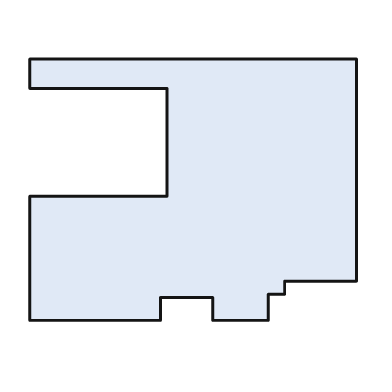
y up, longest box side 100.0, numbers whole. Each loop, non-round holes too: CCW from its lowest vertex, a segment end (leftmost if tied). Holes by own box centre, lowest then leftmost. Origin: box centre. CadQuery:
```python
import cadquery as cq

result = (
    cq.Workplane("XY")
    .moveTo(-50.0, -40.0)
    .lineTo(-10.0, -40.0)
    .lineTo(-10.0, -33.0)
    .lineTo(6.0, -33.0)
    .lineTo(6.0, -40.0)
    .lineTo(23.0, -40.0)
    .lineTo(23.0, -32.0)
    .lineTo(28.0, -32.0)
    .lineTo(28.0, -28.0)
    .lineTo(50.0, -28.0)
    .lineTo(50.0, 40.0)
    .lineTo(-50.0, 40.0)
    .lineTo(-50.0, 31.0)
    .lineTo(-8.0, 31.0)
    .lineTo(-8.0, -2.0)
    .lineTo(-50.0, -2.0)
    .close()
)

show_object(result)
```